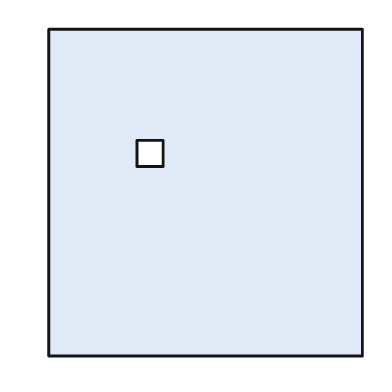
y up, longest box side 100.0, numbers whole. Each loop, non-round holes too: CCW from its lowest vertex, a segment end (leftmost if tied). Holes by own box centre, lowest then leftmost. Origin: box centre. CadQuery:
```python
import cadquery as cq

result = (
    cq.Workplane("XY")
    .moveTo(-48.0, -50.0)
    .lineTo(48.0, -50.0)
    .lineTo(48.0, 50.0)
    .lineTo(-48.0, 50.0)
    .close()
    .moveTo(-21.0, 8.0)
    .lineTo(-13.0, 8.0)
    .lineTo(-13.0, 16.0)
    .lineTo(-21.0, 16.0)
    .close()
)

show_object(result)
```